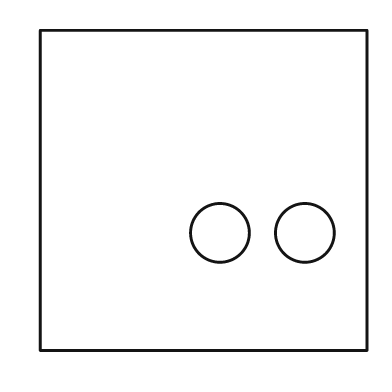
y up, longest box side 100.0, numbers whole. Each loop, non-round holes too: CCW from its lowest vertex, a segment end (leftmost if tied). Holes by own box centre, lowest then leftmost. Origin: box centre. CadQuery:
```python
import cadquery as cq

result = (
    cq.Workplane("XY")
    .moveTo(-50.0, -49.0)
    .lineTo(50.0, -49.0)
    .lineTo(50.0, 49.0)
    .lineTo(-50.0, 49.0)
    .close()
    .moveTo(5.0, -13.0)
    .circle(9.0)
    .moveTo(31.0, -13.0)
    .circle(9.0)
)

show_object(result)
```